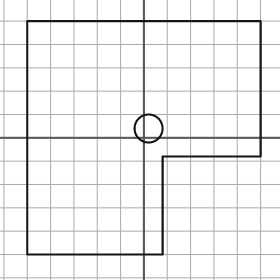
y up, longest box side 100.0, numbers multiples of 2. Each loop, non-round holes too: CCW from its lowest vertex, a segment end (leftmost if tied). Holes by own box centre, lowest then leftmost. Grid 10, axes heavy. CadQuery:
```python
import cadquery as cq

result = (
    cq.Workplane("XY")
    .moveTo(-50.0, -50.0)
    .lineTo(8.0, -50.0)
    .lineTo(8.0, -8.0)
    .lineTo(50.0, -8.0)
    .lineTo(50.0, 50.0)
    .lineTo(-50.0, 50.0)
    .close()
    .moveTo(2.0, 4.0)
    .circle(6.0)
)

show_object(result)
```